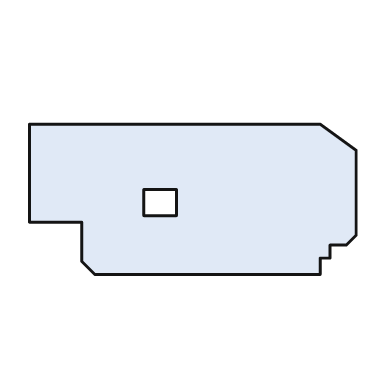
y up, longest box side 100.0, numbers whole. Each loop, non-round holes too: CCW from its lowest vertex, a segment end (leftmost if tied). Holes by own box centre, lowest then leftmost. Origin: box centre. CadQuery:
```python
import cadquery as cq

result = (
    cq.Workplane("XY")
    .moveTo(-30.0, -23.0)
    .lineTo(39.0, -23.0)
    .lineTo(39.0, -18.0)
    .lineTo(42.0, -18.0)
    .lineTo(42.0, -14.0)
    .lineTo(47.0, -14.0)
    .lineTo(50.0, -11.0)
    .lineTo(50.0, 15.0)
    .lineTo(39.0, 23.0)
    .lineTo(-50.0, 23.0)
    .lineTo(-50.0, -7.0)
    .lineTo(-34.0, -7.0)
    .lineTo(-34.0, -19.0)
    .close()
    .moveTo(-15.0, -5.0)
    .lineTo(-5.0, -5.0)
    .lineTo(-5.0, 3.0)
    .lineTo(-15.0, 3.0)
    .close()
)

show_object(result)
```